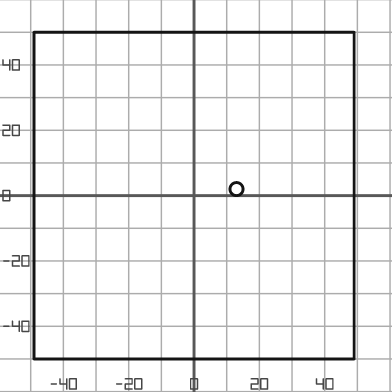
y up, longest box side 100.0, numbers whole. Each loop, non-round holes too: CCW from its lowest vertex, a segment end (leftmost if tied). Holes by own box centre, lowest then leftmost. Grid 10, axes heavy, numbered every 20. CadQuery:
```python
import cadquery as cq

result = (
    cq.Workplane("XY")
    .moveTo(-49.0, -50.0)
    .lineTo(49.0, -50.0)
    .lineTo(49.0, 50.0)
    .lineTo(-49.0, 50.0)
    .close()
    .moveTo(13.0, 2.0)
    .circle(2.0)
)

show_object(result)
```